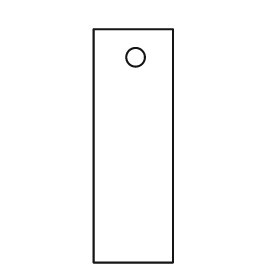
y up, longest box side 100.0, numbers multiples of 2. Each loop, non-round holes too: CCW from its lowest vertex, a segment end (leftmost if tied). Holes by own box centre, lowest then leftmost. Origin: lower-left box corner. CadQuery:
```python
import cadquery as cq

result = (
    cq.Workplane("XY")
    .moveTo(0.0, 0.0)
    .lineTo(34.0, 0.0)
    .lineTo(34.0, 100.0)
    .lineTo(0.0, 100.0)
    .close()
    .moveTo(18.0, 88.0)
    .circle(4.0)
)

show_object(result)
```